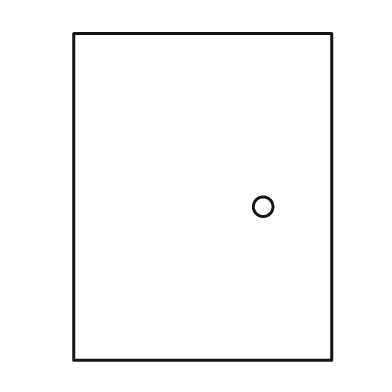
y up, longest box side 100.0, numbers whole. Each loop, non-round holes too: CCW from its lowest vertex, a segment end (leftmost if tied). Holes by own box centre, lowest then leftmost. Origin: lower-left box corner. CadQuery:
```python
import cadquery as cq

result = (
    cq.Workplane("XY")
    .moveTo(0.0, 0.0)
    .lineTo(79.0, 0.0)
    .lineTo(79.0, 100.0)
    .lineTo(0.0, 100.0)
    .close()
    .moveTo(58.0, 47.0)
    .circle(3.0)
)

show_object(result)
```